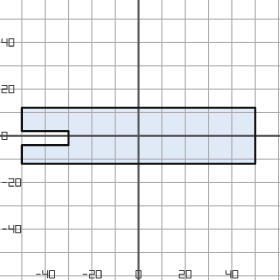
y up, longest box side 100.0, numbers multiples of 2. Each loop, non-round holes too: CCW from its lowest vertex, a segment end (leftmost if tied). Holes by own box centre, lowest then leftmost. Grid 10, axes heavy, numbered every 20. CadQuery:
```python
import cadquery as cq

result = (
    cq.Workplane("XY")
    .moveTo(-50.0, -12.0)
    .lineTo(50.0, -12.0)
    .lineTo(50.0, 12.0)
    .lineTo(-50.0, 12.0)
    .lineTo(-50.0, 2.0)
    .lineTo(-30.0, 2.0)
    .lineTo(-30.0, -4.0)
    .lineTo(-50.0, -4.0)
    .close()
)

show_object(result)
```